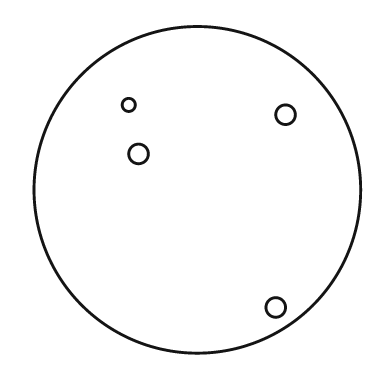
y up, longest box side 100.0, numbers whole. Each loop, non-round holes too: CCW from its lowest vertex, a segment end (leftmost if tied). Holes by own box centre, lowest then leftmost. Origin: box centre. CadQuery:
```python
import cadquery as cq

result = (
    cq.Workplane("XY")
    .moveTo(0.0, 0.0)
    .circle(50.0)
    .moveTo(24.0, -36.0)
    .circle(3.0)
    .moveTo(-18.0, 11.0)
    .circle(3.0)
    .moveTo(27.0, 23.0)
    .circle(3.0)
    .moveTo(-21.0, 26.0)
    .circle(2.0)
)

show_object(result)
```